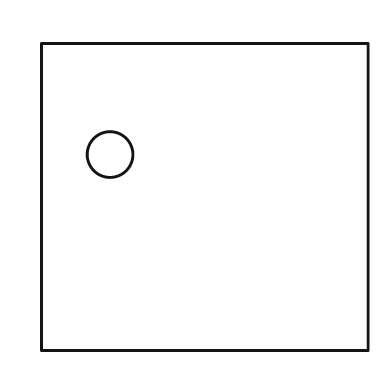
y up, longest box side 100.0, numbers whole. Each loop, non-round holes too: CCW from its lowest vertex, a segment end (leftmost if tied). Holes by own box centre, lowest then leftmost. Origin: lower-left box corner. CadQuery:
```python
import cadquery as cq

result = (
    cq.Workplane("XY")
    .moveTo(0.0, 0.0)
    .lineTo(100.0, 0.0)
    .lineTo(100.0, 94.0)
    .lineTo(0.0, 94.0)
    .close()
    .moveTo(21.0, 60.0)
    .circle(7.0)
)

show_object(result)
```